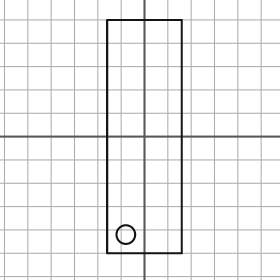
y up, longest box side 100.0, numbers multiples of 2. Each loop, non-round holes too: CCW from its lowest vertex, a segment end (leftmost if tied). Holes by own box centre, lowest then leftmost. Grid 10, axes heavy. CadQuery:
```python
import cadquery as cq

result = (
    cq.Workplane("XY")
    .moveTo(-16.0, -50.0)
    .lineTo(16.0, -50.0)
    .lineTo(16.0, 50.0)
    .lineTo(-16.0, 50.0)
    .close()
    .moveTo(-8.0, -42.0)
    .circle(4.0)
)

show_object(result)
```